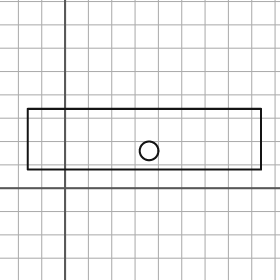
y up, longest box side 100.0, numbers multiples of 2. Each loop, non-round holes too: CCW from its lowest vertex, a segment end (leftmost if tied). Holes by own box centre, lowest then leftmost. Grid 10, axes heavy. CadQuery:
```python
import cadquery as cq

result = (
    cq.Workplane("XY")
    .moveTo(-16.0, 8.0)
    .lineTo(84.0, 8.0)
    .lineTo(84.0, 34.0)
    .lineTo(-16.0, 34.0)
    .close()
    .moveTo(36.0, 16.0)
    .circle(4.0)
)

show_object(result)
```